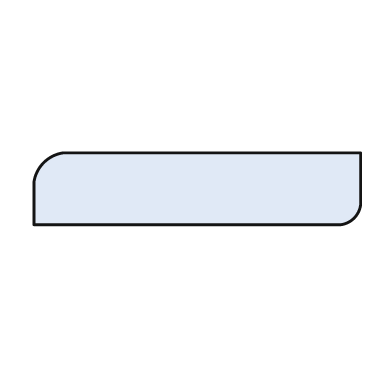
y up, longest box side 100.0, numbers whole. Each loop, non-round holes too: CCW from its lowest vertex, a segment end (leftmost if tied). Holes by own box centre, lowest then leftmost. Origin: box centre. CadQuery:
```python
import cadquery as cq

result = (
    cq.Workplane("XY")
    .moveTo(-50.0, -11.0)
    .lineTo(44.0, -11.0)
    .threePointArc((48.0, -9.0), (50.0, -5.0))
    .lineTo(50.0, 11.0)
    .lineTo(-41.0, 11.0)
    .threePointArc((-47.0, 8.0), (-50.0, 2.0))
    .close()
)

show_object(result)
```